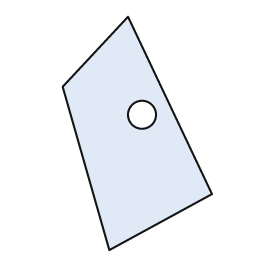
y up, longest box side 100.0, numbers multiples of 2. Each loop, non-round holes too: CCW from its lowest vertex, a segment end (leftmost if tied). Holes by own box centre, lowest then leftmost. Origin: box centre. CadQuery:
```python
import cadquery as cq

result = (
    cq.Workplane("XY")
    .moveTo(-12.0, -50.0)
    .lineTo(32.0, -26.0)
    .lineTo(-4.0, 50.0)
    .lineTo(-32.0, 20.0)
    .close()
    .moveTo(2.0, 8.0)
    .circle(6.0)
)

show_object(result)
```